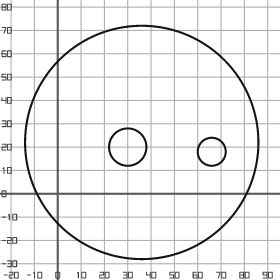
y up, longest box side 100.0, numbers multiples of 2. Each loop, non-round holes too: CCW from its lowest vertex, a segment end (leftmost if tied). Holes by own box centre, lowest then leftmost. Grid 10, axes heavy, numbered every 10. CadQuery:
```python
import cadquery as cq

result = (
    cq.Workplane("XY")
    .moveTo(36.0, 22.0)
    .circle(50.0)
    .moveTo(66.0, 18.0)
    .circle(6.0)
    .moveTo(30.0, 20.0)
    .circle(8.0)
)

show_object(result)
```